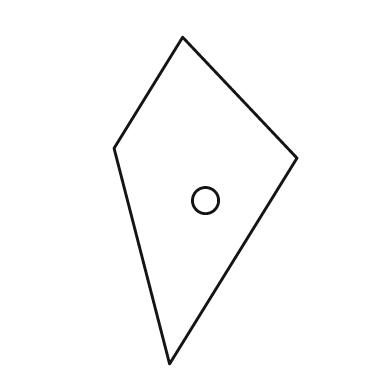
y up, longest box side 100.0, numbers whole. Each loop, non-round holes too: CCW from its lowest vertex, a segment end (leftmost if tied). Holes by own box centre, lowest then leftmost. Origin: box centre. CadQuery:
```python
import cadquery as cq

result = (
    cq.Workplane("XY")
    .moveTo(-11.0, -50.0)
    .lineTo(28.0, 13.0)
    .lineTo(-7.0, 50.0)
    .lineTo(-28.0, 16.0)
    .close()
    .moveTo(0.0, 0.0)
    .circle(4.0)
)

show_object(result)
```